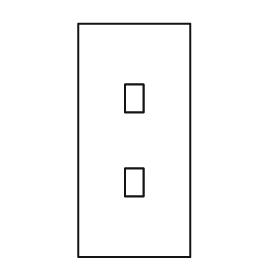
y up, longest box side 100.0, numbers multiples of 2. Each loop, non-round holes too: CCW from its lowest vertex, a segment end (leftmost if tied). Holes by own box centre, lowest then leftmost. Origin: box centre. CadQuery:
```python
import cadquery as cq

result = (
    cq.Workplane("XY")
    .moveTo(-24.0, -50.0)
    .lineTo(24.0, -50.0)
    .lineTo(24.0, 50.0)
    .lineTo(-24.0, 50.0)
    .close()
    .moveTo(-4.0, -24.0)
    .lineTo(4.0, -24.0)
    .lineTo(4.0, -12.0)
    .lineTo(-4.0, -12.0)
    .close()
    .moveTo(-4.0, 12.0)
    .lineTo(4.0, 12.0)
    .lineTo(4.0, 24.0)
    .lineTo(-4.0, 24.0)
    .close()
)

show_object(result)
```